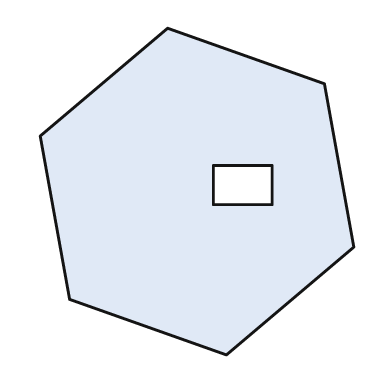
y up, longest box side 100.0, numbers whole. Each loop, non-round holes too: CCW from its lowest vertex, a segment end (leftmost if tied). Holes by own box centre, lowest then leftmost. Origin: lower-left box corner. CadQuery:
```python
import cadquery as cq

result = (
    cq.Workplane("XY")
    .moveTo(57.0, 0.0)
    .lineTo(96.0, 33.0)
    .lineTo(87.0, 83.0)
    .lineTo(39.0, 100.0)
    .lineTo(0.0, 67.0)
    .lineTo(9.0, 17.0)
    .close()
    .moveTo(53.0, 46.0)
    .lineTo(71.0, 46.0)
    .lineTo(71.0, 58.0)
    .lineTo(53.0, 58.0)
    .close()
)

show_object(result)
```